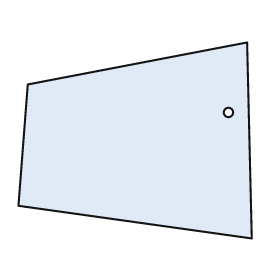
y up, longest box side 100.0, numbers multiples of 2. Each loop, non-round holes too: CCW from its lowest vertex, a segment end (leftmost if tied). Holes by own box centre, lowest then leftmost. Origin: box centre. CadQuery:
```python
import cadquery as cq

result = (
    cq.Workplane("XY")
    .moveTo(50.0, -42.0)
    .lineTo(48.0, 42.0)
    .lineTo(-46.0, 24.0)
    .lineTo(-50.0, -28.0)
    .close()
    .moveTo(40.0, 12.0)
    .circle(2.0)
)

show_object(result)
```